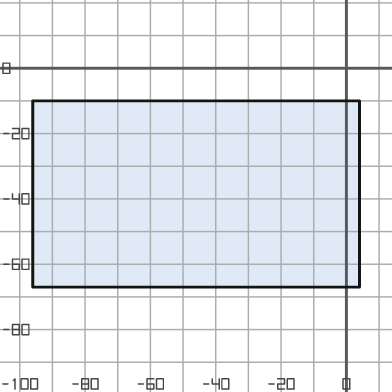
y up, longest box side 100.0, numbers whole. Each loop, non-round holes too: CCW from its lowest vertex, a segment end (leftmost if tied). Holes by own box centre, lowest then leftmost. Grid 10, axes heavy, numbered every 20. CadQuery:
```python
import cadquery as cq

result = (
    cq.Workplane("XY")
    .moveTo(-96.0, -67.0)
    .lineTo(4.0, -67.0)
    .lineTo(4.0, -10.0)
    .lineTo(-96.0, -10.0)
    .close()
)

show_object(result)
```